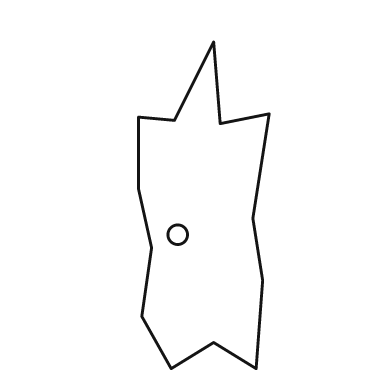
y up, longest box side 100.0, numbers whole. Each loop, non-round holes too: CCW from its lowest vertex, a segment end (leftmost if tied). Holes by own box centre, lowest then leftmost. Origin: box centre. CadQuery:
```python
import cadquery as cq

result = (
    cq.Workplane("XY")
    .moveTo(-10.0, -50.0)
    .lineTo(3.0, -42.0)
    .lineTo(16.0, -50.0)
    .lineTo(18.0, -23.0)
    .lineTo(15.0, -4.0)
    .lineTo(20.0, 28.0)
    .lineTo(5.0, 25.0)
    .lineTo(3.0, 50.0)
    .lineTo(-9.0, 26.0)
    .lineTo(-20.0, 27.0)
    .lineTo(-20.0, 5.0)
    .lineTo(-16.0, -13.0)
    .lineTo(-19.0, -34.0)
    .close()
    .moveTo(-8.0, -9.0)
    .circle(3.0)
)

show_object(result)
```